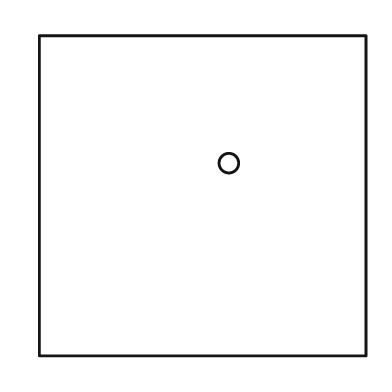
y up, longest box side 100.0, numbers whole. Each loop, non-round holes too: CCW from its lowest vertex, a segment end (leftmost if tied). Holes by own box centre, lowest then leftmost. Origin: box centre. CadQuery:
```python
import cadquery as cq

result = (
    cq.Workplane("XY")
    .moveTo(-50.0, -49.0)
    .lineTo(50.0, -49.0)
    .lineTo(50.0, 49.0)
    .lineTo(-50.0, 49.0)
    .close()
    .moveTo(8.0, 10.0)
    .circle(3.0)
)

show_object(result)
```